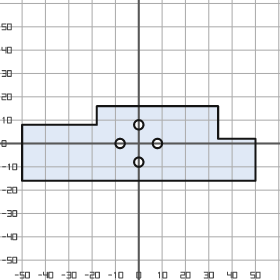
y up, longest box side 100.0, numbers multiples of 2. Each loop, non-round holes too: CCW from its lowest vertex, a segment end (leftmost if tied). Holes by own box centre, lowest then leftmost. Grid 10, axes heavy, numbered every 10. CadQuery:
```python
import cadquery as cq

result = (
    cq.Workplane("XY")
    .moveTo(-50.0, -16.0)
    .lineTo(50.0, -16.0)
    .lineTo(50.0, 2.0)
    .lineTo(34.0, 2.0)
    .lineTo(34.0, 16.0)
    .lineTo(-18.0, 16.0)
    .lineTo(-18.0, 8.0)
    .lineTo(-50.0, 8.0)
    .close()
    .moveTo(0.0, -8.0)
    .circle(2.0)
    .moveTo(-8.0, 0.0)
    .circle(2.0)
    .moveTo(8.0, 0.0)
    .circle(2.0)
    .moveTo(0.0, 8.0)
    .circle(2.0)
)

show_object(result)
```